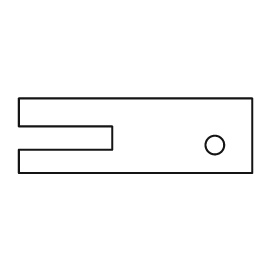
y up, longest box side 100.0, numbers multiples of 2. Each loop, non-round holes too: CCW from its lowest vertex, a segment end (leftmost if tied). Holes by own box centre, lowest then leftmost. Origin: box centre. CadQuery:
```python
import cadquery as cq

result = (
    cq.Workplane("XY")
    .moveTo(-50.0, -16.0)
    .lineTo(50.0, -16.0)
    .lineTo(50.0, 16.0)
    .lineTo(-50.0, 16.0)
    .lineTo(-50.0, 4.0)
    .lineTo(-10.0, 4.0)
    .lineTo(-10.0, -6.0)
    .lineTo(-50.0, -6.0)
    .close()
    .moveTo(34.0, -4.0)
    .circle(4.0)
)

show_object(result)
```